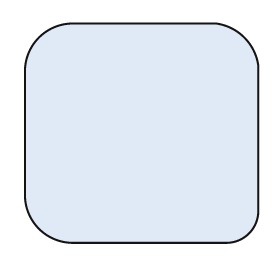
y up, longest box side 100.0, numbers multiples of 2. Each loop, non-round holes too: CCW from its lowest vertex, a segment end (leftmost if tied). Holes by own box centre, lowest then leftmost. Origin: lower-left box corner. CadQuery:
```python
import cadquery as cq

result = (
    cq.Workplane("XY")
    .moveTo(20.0, 0.0)
    .lineTo(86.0, 0.0)
    .threePointArc((96.0, 4.0), (100.0, 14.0))
    .lineTo(100.0, 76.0)
    .threePointArc((94.0, 88.0), (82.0, 94.0))
    .lineTo(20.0, 94.0)
    .threePointArc((6.0, 88.0), (0.0, 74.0))
    .lineTo(0.0, 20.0)
    .threePointArc((6.0, 6.0), (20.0, 0.0))
    .close()
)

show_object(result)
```